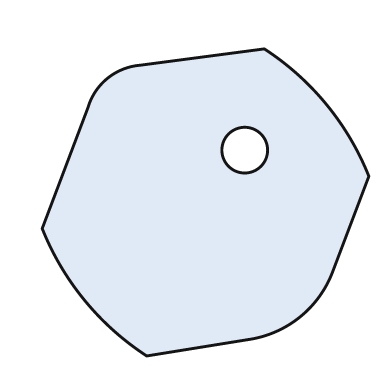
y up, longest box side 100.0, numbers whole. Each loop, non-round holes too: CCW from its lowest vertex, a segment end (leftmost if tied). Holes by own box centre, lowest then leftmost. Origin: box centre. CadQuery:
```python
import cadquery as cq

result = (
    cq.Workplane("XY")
    .moveTo(-18.0, -47.0)
    .lineTo(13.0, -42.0)
    .threePointArc((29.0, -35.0), (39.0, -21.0))
    .lineTo(50.0, 8.0)
    .threePointArc((37.0, 30.0), (18.0, 47.0))
    .lineTo(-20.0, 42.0)
    .threePointArc((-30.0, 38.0), (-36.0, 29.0))
    .lineTo(-50.0, -8.0)
    .threePointArc((-37.0, -30.0), (-18.0, -47.0))
    .close()
    .moveTo(12.0, 16.0)
    .circle(7.0)
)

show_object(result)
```